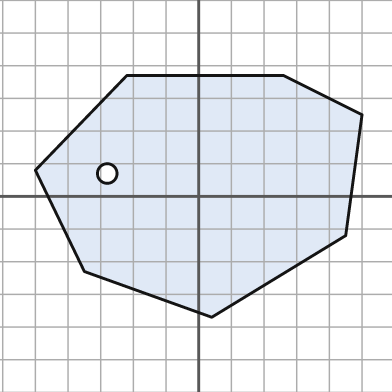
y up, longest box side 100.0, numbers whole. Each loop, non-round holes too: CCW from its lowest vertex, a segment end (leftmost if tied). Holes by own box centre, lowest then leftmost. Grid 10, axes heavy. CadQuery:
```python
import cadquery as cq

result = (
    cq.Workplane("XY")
    .moveTo(4.0, -37.0)
    .lineTo(45.0, -12.0)
    .lineTo(50.0, 25.0)
    .lineTo(26.0, 37.0)
    .lineTo(-22.0, 37.0)
    .lineTo(-50.0, 8.0)
    .lineTo(-35.0, -23.0)
    .close()
    .moveTo(-28.0, 7.0)
    .circle(3.0)
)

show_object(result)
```